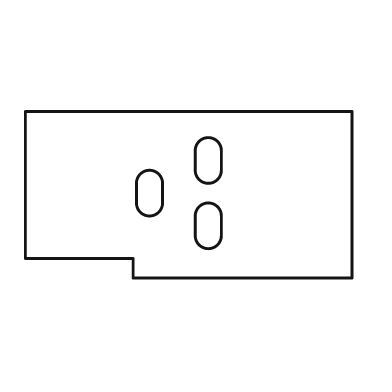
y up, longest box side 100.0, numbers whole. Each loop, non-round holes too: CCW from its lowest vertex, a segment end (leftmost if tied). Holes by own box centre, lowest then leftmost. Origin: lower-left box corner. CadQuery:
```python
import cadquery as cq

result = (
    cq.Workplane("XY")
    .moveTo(33.0, 0.0)
    .lineTo(100.0, 0.0)
    .lineTo(100.0, 51.0)
    .lineTo(0.0, 51.0)
    .lineTo(0.0, 6.0)
    .lineTo(33.0, 6.0)
    .close()
    .moveTo(52.0, 13.0)
    .threePointArc((56.0, 9.0), (60.0, 13.0))
    .lineTo(60.0, 19.0)
    .threePointArc((56.0, 23.0), (52.0, 19.0))
    .close()
    .moveTo(34.0, 23.0)
    .threePointArc((38.0, 19.0), (42.0, 23.0))
    .lineTo(42.0, 29.0)
    .threePointArc((38.0, 33.0), (34.0, 29.0))
    .close()
    .moveTo(52.0, 33.0)
    .threePointArc((56.0, 29.0), (60.0, 33.0))
    .lineTo(60.0, 39.0)
    .threePointArc((56.0, 43.0), (52.0, 39.0))
    .close()
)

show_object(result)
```